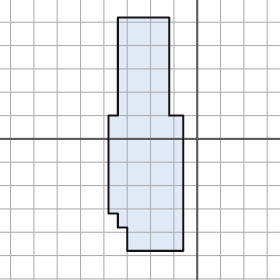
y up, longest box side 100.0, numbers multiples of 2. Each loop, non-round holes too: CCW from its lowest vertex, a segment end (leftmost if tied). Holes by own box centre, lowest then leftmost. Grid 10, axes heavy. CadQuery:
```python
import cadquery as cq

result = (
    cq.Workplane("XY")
    .moveTo(-30.0, -48.0)
    .lineTo(-6.0, -48.0)
    .lineTo(-6.0, 10.0)
    .lineTo(-12.0, 10.0)
    .lineTo(-12.0, 52.0)
    .lineTo(-34.0, 52.0)
    .lineTo(-34.0, 10.0)
    .lineTo(-38.0, 10.0)
    .lineTo(-38.0, -32.0)
    .lineTo(-34.0, -32.0)
    .lineTo(-34.0, -38.0)
    .lineTo(-30.0, -38.0)
    .close()
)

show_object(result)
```